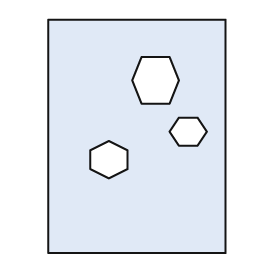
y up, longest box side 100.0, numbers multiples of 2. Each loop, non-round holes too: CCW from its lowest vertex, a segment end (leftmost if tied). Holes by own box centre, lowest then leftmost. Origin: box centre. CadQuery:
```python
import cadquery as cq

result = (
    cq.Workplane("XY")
    .moveTo(-38.0, -50.0)
    .lineTo(38.0, -50.0)
    .lineTo(38.0, 50.0)
    .lineTo(-38.0, 50.0)
    .close()
    .moveTo(-12.0, -18.0)
    .lineTo(-4.0, -14.0)
    .lineTo(-4.0, -6.0)
    .lineTo(-12.0, -2.0)
    .lineTo(-20.0, -6.0)
    .lineTo(-20.0, -14.0)
    .close()
    .moveTo(18.0, -4.0)
    .lineTo(26.0, -4.0)
    .lineTo(30.0, 2.0)
    .lineTo(26.0, 8.0)
    .lineTo(18.0, 8.0)
    .lineTo(14.0, 2.0)
    .close()
    .moveTo(2.0, 14.0)
    .lineTo(14.0, 14.0)
    .lineTo(18.0, 24.0)
    .lineTo(14.0, 34.0)
    .lineTo(2.0, 34.0)
    .lineTo(-2.0, 24.0)
    .close()
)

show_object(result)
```